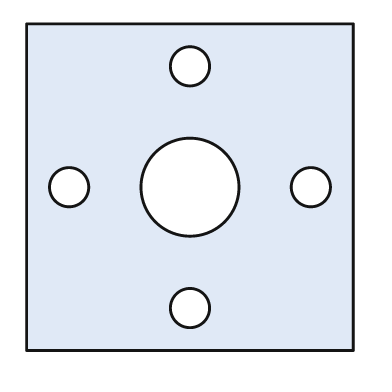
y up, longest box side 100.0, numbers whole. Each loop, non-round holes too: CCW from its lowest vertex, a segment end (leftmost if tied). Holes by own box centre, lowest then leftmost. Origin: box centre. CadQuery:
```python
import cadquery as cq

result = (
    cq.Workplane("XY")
    .moveTo(-50.0, -50.0)
    .lineTo(50.0, -50.0)
    .lineTo(50.0, 50.0)
    .lineTo(-50.0, 50.0)
    .close()
    .moveTo(0.0, -37.0)
    .circle(6.0)
    .moveTo(-37.0, 0.0)
    .circle(6.0)
    .moveTo(0.0, 0.0)
    .circle(15.0)
    .moveTo(37.0, 0.0)
    .circle(6.0)
    .moveTo(0.0, 37.0)
    .circle(6.0)
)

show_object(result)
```